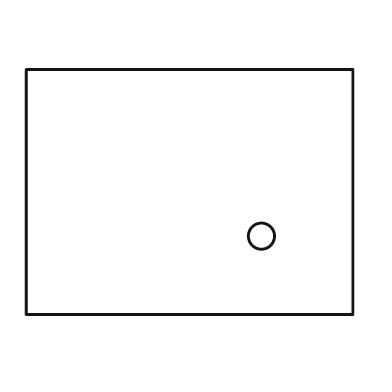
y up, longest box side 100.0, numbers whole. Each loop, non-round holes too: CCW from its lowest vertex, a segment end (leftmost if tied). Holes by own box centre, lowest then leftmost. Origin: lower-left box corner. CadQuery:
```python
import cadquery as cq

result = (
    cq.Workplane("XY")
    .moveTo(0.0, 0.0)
    .lineTo(100.0, 0.0)
    .lineTo(100.0, 75.0)
    .lineTo(0.0, 75.0)
    .close()
    .moveTo(72.0, 24.0)
    .circle(4.0)
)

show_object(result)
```